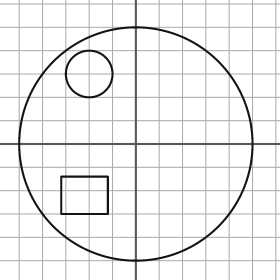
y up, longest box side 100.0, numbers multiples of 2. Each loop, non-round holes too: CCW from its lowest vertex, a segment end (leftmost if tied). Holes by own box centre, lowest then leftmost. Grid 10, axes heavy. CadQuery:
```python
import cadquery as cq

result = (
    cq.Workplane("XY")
    .moveTo(0.0, 0.0)
    .circle(50.0)
    .moveTo(-32.0, -30.0)
    .lineTo(-12.0, -30.0)
    .lineTo(-12.0, -14.0)
    .lineTo(-32.0, -14.0)
    .close()
    .moveTo(-20.0, 30.0)
    .circle(10.0)
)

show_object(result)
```